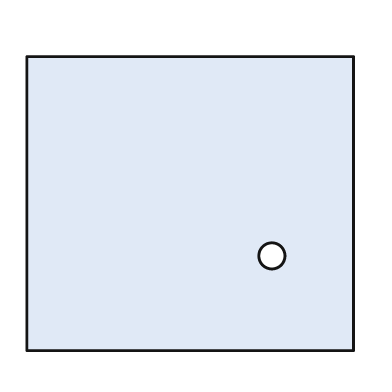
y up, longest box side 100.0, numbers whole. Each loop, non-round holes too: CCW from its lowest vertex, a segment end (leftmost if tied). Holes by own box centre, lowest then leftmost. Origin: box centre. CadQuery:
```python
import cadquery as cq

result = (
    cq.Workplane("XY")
    .moveTo(-50.0, -45.0)
    .lineTo(50.0, -45.0)
    .lineTo(50.0, 45.0)
    .lineTo(-50.0, 45.0)
    .close()
    .moveTo(25.0, -16.0)
    .circle(4.0)
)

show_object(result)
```